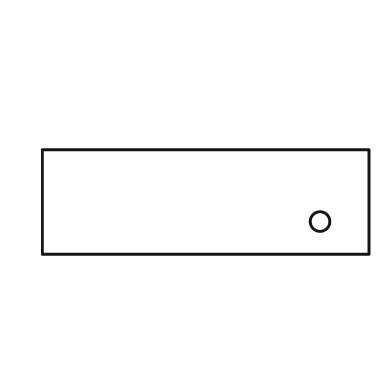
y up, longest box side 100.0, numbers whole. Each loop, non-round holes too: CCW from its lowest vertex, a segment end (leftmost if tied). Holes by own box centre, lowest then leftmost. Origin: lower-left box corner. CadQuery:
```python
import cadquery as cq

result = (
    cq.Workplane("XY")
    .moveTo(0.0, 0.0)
    .lineTo(100.0, 0.0)
    .lineTo(100.0, 32.0)
    .lineTo(0.0, 32.0)
    .close()
    .moveTo(85.0, 10.0)
    .circle(3.0)
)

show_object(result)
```